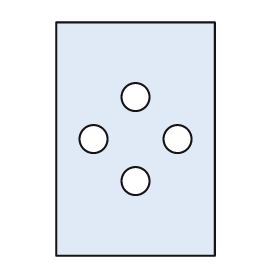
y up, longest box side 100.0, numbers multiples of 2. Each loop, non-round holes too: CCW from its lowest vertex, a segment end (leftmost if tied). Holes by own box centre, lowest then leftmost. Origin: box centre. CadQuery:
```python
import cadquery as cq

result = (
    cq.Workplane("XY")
    .moveTo(-34.0, -50.0)
    .lineTo(34.0, -50.0)
    .lineTo(34.0, 50.0)
    .lineTo(-34.0, 50.0)
    .close()
    .moveTo(0.0, -18.0)
    .circle(6.0)
    .moveTo(-18.0, 0.0)
    .circle(6.0)
    .moveTo(18.0, 0.0)
    .circle(6.0)
    .moveTo(0.0, 18.0)
    .circle(6.0)
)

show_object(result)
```